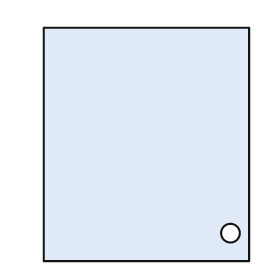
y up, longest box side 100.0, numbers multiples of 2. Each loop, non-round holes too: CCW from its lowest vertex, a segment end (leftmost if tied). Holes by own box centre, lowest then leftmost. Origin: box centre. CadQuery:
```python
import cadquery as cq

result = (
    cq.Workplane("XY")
    .moveTo(-44.0, -50.0)
    .lineTo(44.0, -50.0)
    .lineTo(44.0, 50.0)
    .lineTo(-44.0, 50.0)
    .close()
    .moveTo(36.0, -38.0)
    .circle(4.0)
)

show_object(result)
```